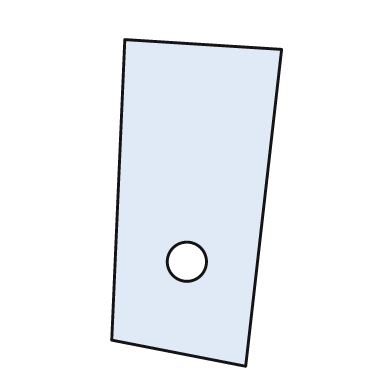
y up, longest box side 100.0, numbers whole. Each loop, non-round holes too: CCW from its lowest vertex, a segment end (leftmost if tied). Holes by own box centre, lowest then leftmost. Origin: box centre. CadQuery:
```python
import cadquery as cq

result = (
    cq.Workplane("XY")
    .moveTo(15.0, -50.0)
    .lineTo(26.0, 47.0)
    .lineTo(-22.0, 50.0)
    .lineTo(-26.0, -42.0)
    .close()
    .moveTo(-3.0, -18.0)
    .circle(6.0)
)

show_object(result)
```